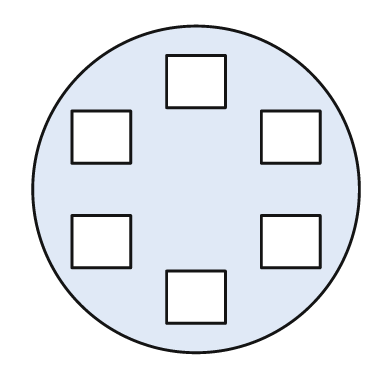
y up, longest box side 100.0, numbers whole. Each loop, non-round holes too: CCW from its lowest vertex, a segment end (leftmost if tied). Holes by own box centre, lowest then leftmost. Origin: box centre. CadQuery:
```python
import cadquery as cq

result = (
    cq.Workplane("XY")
    .moveTo(0.0, 0.0)
    .circle(50.0)
    .moveTo(-9.0, -41.0)
    .lineTo(9.0, -41.0)
    .lineTo(9.0, -25.0)
    .lineTo(-9.0, -25.0)
    .close()
    .moveTo(-38.0, -24.0)
    .lineTo(-20.0, -24.0)
    .lineTo(-20.0, -8.0)
    .lineTo(-38.0, -8.0)
    .close()
    .moveTo(20.0, -24.0)
    .lineTo(38.0, -24.0)
    .lineTo(38.0, -8.0)
    .lineTo(20.0, -8.0)
    .close()
    .moveTo(-38.0, 8.0)
    .lineTo(-20.0, 8.0)
    .lineTo(-20.0, 24.0)
    .lineTo(-38.0, 24.0)
    .close()
    .moveTo(20.0, 8.0)
    .lineTo(38.0, 8.0)
    .lineTo(38.0, 24.0)
    .lineTo(20.0, 24.0)
    .close()
    .moveTo(-9.0, 25.0)
    .lineTo(9.0, 25.0)
    .lineTo(9.0, 41.0)
    .lineTo(-9.0, 41.0)
    .close()
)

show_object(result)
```